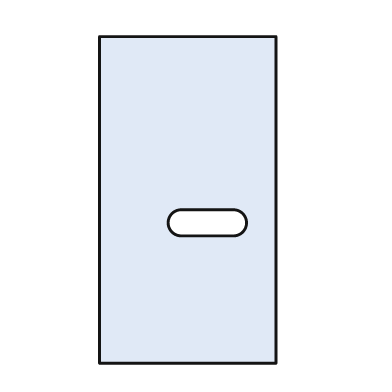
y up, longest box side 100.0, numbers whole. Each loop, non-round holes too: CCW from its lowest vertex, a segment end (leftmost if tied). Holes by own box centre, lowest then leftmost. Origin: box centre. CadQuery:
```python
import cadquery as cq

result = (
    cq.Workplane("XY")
    .moveTo(-27.0, -50.0)
    .lineTo(27.0, -50.0)
    .lineTo(27.0, 50.0)
    .lineTo(-27.0, 50.0)
    .close()
    .moveTo(-2.0, -11.0)
    .lineTo(14.0, -11.0)
    .threePointArc((18.0, -7.0), (14.0, -3.0))
    .lineTo(-2.0, -3.0)
    .threePointArc((-6.0, -7.0), (-2.0, -11.0))
    .close()
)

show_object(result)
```